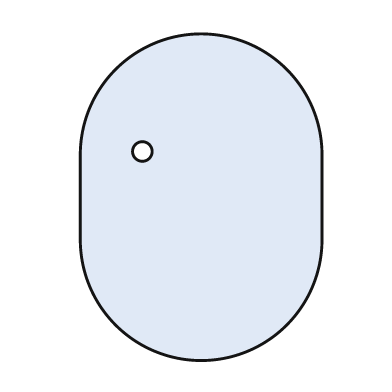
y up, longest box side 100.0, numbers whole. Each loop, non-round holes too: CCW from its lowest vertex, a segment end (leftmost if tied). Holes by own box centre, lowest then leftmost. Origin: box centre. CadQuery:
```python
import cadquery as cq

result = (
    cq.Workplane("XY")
    .moveTo(-37.0, -13.0)
    .threePointArc((0.0, -50.0), (37.0, -13.0))
    .lineTo(37.0, 13.0)
    .threePointArc((0.0, 50.0), (-37.0, 13.0))
    .close()
    .moveTo(-18.0, 14.0)
    .circle(3.0)
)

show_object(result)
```